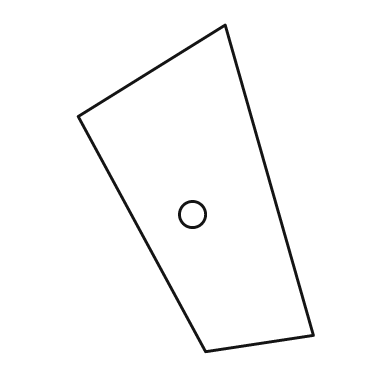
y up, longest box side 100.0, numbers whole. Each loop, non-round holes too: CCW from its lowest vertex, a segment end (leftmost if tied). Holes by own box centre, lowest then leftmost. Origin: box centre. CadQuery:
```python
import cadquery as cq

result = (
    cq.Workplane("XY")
    .moveTo(3.0, -50.0)
    .lineTo(36.0, -45.0)
    .lineTo(9.0, 50.0)
    .lineTo(-36.0, 22.0)
    .close()
    .moveTo(-1.0, -8.0)
    .circle(4.0)
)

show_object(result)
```